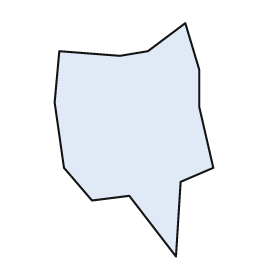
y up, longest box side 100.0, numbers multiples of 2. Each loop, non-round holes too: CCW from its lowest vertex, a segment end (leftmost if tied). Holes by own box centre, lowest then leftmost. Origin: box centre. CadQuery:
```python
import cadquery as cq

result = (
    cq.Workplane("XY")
    .moveTo(18.0, -50.0)
    .lineTo(20.0, -18.0)
    .lineTo(34.0, -12.0)
    .lineTo(28.0, 14.0)
    .lineTo(28.0, 30.0)
    .lineTo(22.0, 50.0)
    .lineTo(6.0, 38.0)
    .lineTo(-6.0, 36.0)
    .lineTo(-32.0, 38.0)
    .lineTo(-34.0, 16.0)
    .lineTo(-30.0, -12.0)
    .lineTo(-18.0, -26.0)
    .lineTo(-2.0, -24.0)
    .close()
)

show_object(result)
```